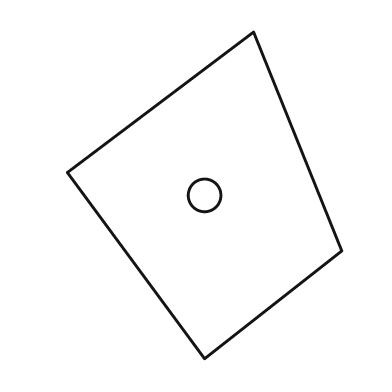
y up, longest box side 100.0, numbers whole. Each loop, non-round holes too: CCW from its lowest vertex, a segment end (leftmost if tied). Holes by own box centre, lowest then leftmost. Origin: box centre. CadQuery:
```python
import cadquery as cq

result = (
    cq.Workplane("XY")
    .moveTo(0.0, -50.0)
    .lineTo(42.0, -17.0)
    .lineTo(15.0, 50.0)
    .lineTo(-42.0, 7.0)
    .close()
    .moveTo(0.0, 0.0)
    .circle(5.0)
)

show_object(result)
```